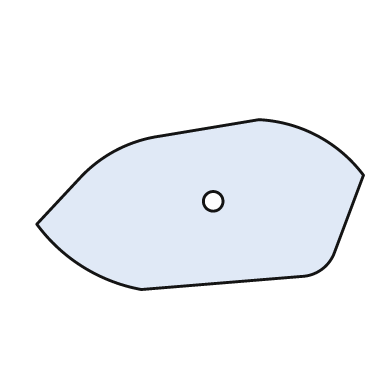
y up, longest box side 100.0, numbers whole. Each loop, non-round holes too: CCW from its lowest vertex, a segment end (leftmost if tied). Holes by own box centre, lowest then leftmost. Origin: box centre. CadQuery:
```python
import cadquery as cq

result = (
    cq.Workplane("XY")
    .moveTo(-18.0, -26.0)
    .lineTo(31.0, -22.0)
    .threePointArc((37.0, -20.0), (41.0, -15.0))
    .lineTo(50.0, 9.0)
    .threePointArc((36.0, 21.0), (18.0, 26.0))
    .lineTo(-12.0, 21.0)
    .threePointArc((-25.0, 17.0), (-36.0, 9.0))
    .lineTo(-50.0, -6.0)
    .threePointArc((-36.0, -19.0), (-18.0, -26.0))
    .close()
    .moveTo(4.0, 1.0)
    .circle(3.0)
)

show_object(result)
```